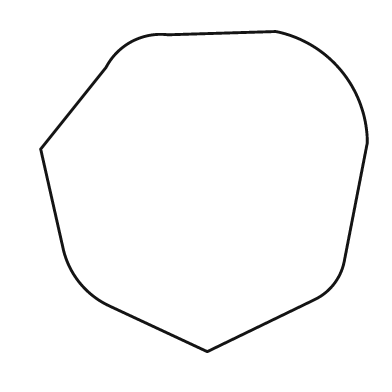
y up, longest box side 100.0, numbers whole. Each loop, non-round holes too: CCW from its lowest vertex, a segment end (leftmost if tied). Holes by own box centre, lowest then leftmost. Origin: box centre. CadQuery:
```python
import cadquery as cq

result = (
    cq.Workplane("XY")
    .moveTo(1.0, -49.0)
    .lineTo(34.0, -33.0)
    .threePointArc((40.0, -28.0), (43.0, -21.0))
    .lineTo(50.0, 15.0)
    .threePointArc((42.0, 37.0), (22.0, 49.0))
    .lineTo(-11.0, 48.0)
    .threePointArc((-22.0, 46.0), (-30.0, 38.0))
    .lineTo(-50.0, 13.0)
    .lineTo(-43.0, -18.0)
    .threePointArc((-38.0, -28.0), (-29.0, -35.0))
    .close()
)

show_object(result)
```